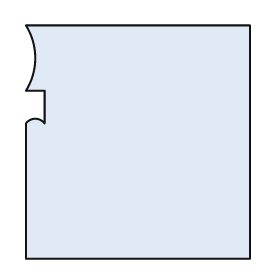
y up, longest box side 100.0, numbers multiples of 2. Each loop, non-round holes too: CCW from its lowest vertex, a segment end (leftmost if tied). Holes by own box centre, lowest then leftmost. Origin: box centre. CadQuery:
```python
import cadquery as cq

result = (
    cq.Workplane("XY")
    .moveTo(-48.0, -50.0)
    .lineTo(48.0, -50.0)
    .lineTo(48.0, 50.0)
    .lineTo(-48.0, 50.0)
    .threePointArc((-44.0, 36.0), (-48.0, 22.0))
    .lineTo(-40.0, 22.0)
    .lineTo(-40.0, 8.0)
    .threePointArc((-44.0, 10.0), (-48.0, 8.0))
    .close()
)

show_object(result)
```